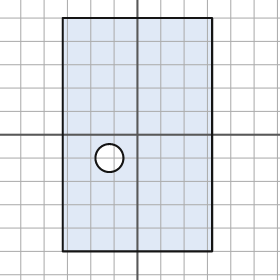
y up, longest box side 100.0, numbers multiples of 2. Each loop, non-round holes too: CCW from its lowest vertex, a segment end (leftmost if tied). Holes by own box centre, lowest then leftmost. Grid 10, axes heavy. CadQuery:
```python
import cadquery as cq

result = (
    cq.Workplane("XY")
    .moveTo(-32.0, -50.0)
    .lineTo(32.0, -50.0)
    .lineTo(32.0, 50.0)
    .lineTo(-32.0, 50.0)
    .close()
    .moveTo(-12.0, -10.0)
    .circle(6.0)
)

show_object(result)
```